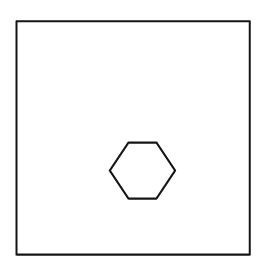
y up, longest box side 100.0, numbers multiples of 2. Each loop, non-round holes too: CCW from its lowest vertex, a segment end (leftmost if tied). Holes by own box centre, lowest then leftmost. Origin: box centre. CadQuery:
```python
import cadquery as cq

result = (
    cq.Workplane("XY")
    .moveTo(-50.0, -50.0)
    .lineTo(50.0, -50.0)
    .lineTo(50.0, 50.0)
    .lineTo(-50.0, 50.0)
    .close()
    .moveTo(-2.0, -26.0)
    .lineTo(10.0, -26.0)
    .lineTo(18.0, -14.0)
    .lineTo(10.0, -2.0)
    .lineTo(-2.0, -2.0)
    .lineTo(-10.0, -14.0)
    .close()
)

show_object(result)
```